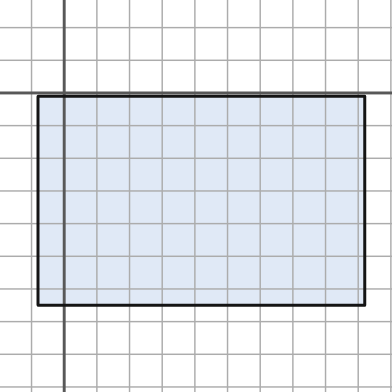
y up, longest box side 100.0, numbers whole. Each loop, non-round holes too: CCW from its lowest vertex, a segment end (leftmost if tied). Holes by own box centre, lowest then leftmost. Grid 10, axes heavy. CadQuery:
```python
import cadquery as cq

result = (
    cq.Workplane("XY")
    .moveTo(-8.0, -65.0)
    .lineTo(92.0, -65.0)
    .lineTo(92.0, -1.0)
    .lineTo(-8.0, -1.0)
    .close()
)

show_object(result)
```